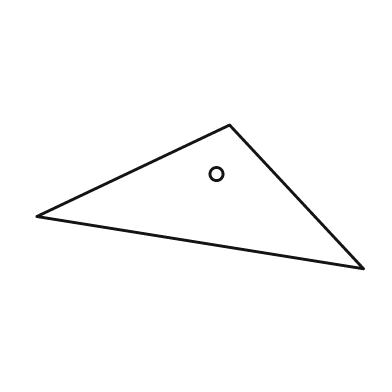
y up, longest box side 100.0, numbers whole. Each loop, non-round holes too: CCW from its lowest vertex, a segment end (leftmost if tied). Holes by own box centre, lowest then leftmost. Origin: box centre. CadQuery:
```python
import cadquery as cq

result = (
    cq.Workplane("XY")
    .moveTo(50.0, -22.0)
    .lineTo(9.0, 22.0)
    .lineTo(-50.0, -6.0)
    .close()
    .moveTo(5.0, 7.0)
    .circle(2.0)
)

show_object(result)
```